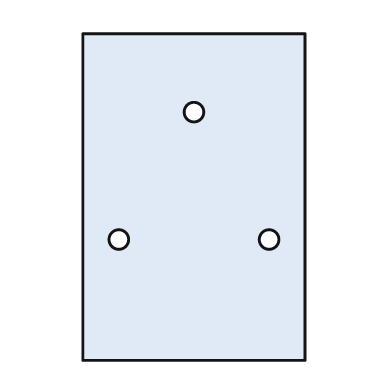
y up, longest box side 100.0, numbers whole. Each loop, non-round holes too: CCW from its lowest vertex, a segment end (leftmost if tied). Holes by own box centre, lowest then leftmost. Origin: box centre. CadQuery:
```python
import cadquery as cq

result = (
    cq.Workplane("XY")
    .moveTo(-34.0, -50.0)
    .lineTo(34.0, -50.0)
    .lineTo(34.0, 50.0)
    .lineTo(-34.0, 50.0)
    .close()
    .moveTo(-23.0, -13.0)
    .circle(3.0)
    .moveTo(23.0, -13.0)
    .circle(3.0)
    .moveTo(0.0, 26.0)
    .circle(3.0)
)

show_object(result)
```